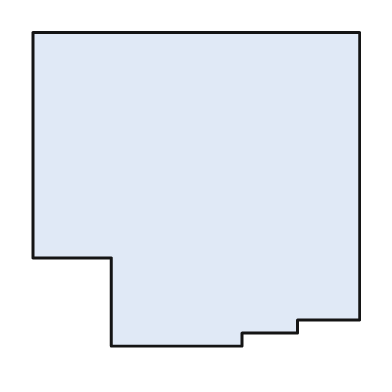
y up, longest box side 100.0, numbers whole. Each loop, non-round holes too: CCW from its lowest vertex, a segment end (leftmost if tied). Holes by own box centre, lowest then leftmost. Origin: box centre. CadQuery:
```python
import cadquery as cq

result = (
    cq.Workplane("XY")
    .moveTo(-26.0, -48.0)
    .lineTo(14.0, -48.0)
    .lineTo(14.0, -44.0)
    .lineTo(31.0, -44.0)
    .lineTo(31.0, -40.0)
    .lineTo(50.0, -40.0)
    .lineTo(50.0, 48.0)
    .lineTo(-50.0, 48.0)
    .lineTo(-50.0, -21.0)
    .lineTo(-26.0, -21.0)
    .close()
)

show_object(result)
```